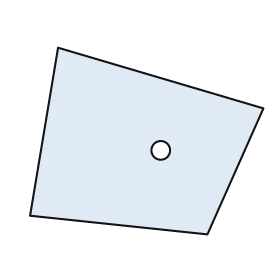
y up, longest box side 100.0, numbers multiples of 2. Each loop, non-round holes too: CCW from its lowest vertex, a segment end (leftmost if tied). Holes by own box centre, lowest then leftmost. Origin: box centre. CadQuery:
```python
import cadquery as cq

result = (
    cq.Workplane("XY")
    .moveTo(26.0, -40.0)
    .lineTo(50.0, 14.0)
    .lineTo(-38.0, 40.0)
    .lineTo(-50.0, -32.0)
    .close()
    .moveTo(6.0, -4.0)
    .circle(4.0)
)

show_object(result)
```